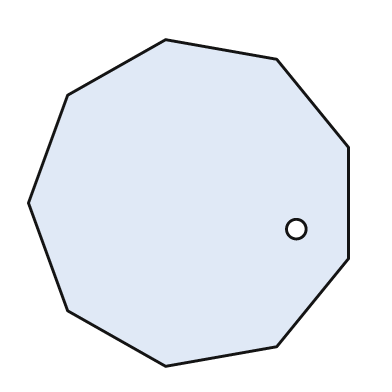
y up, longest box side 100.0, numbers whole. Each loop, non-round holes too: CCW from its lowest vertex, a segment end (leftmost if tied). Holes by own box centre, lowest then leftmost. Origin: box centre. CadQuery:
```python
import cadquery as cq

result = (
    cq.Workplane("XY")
    .moveTo(-7.0, -50.0)
    .lineTo(27.0, -44.0)
    .lineTo(49.0, -17.0)
    .lineTo(49.0, 17.0)
    .lineTo(27.0, 44.0)
    .lineTo(-7.0, 50.0)
    .lineTo(-37.0, 33.0)
    .lineTo(-49.0, 0.0)
    .lineTo(-37.0, -33.0)
    .close()
    .moveTo(33.0, -8.0)
    .circle(3.0)
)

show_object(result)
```